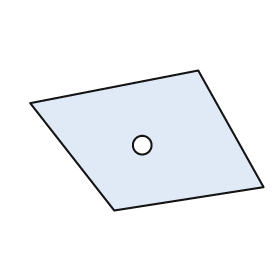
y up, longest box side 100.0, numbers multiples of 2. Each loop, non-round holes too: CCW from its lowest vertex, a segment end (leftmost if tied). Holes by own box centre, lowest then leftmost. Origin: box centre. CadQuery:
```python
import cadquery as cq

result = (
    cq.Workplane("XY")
    .moveTo(-14.0, -30.0)
    .lineTo(50.0, -20.0)
    .lineTo(22.0, 30.0)
    .lineTo(-50.0, 16.0)
    .close()
    .moveTo(-2.0, -2.0)
    .circle(4.0)
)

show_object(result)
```